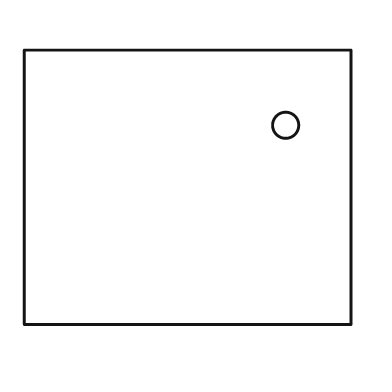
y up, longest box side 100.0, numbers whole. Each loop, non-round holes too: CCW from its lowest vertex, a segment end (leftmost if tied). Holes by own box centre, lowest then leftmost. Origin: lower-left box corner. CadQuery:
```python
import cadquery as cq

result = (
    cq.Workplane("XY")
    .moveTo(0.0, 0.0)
    .lineTo(100.0, 0.0)
    .lineTo(100.0, 84.0)
    .lineTo(0.0, 84.0)
    .close()
    .moveTo(80.0, 61.0)
    .circle(4.0)
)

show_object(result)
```